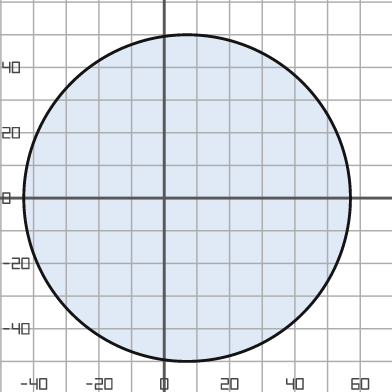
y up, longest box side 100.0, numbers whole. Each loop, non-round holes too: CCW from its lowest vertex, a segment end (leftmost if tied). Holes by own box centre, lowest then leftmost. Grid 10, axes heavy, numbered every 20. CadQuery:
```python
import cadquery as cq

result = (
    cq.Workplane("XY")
    .moveTo(7.0, 0.0)
    .circle(50.0)
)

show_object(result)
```